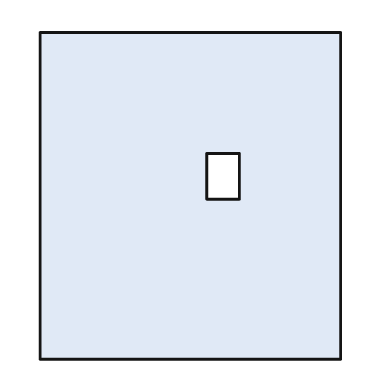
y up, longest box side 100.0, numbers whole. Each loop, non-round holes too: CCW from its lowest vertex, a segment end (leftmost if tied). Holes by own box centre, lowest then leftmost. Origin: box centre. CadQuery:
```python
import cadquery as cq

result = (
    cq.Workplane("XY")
    .moveTo(-46.0, -50.0)
    .lineTo(46.0, -50.0)
    .lineTo(46.0, 50.0)
    .lineTo(-46.0, 50.0)
    .close()
    .moveTo(5.0, -1.0)
    .lineTo(15.0, -1.0)
    .lineTo(15.0, 13.0)
    .lineTo(5.0, 13.0)
    .close()
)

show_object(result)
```